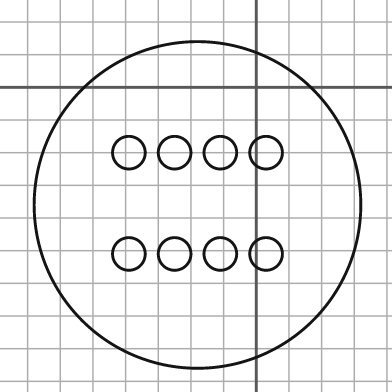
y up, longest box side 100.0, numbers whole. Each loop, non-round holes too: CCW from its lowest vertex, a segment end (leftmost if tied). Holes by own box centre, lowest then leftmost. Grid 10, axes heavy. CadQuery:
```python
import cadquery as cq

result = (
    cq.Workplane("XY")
    .moveTo(-18.0, -36.0)
    .circle(50.0)
    .moveTo(-39.0, -51.0)
    .circle(5.0)
    .moveTo(-25.0, -51.0)
    .circle(5.0)
    .moveTo(-11.0, -51.0)
    .circle(5.0)
    .moveTo(3.0, -51.0)
    .circle(5.0)
    .moveTo(-39.0, -20.0)
    .circle(5.0)
    .moveTo(-25.0, -20.0)
    .circle(5.0)
    .moveTo(-11.0, -20.0)
    .circle(5.0)
    .moveTo(3.0, -20.0)
    .circle(5.0)
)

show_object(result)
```